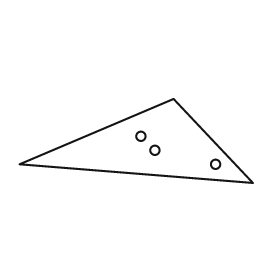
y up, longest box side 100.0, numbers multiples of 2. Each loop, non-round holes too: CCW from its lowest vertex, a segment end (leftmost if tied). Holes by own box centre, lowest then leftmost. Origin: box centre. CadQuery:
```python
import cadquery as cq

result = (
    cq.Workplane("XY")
    .moveTo(50.0, -18.0)
    .lineTo(16.0, 18.0)
    .lineTo(-50.0, -10.0)
    .close()
    .moveTo(34.0, -10.0)
    .circle(2.0)
    .moveTo(8.0, -4.0)
    .circle(2.0)
    .moveTo(2.0, 2.0)
    .circle(2.0)
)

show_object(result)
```